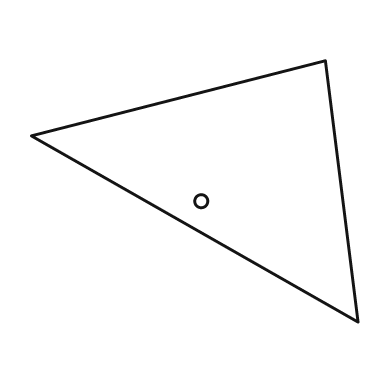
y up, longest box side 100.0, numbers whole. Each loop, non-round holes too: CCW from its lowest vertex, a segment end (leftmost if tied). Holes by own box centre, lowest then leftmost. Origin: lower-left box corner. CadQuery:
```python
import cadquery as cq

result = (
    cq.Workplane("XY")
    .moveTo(100.0, 0.0)
    .lineTo(90.0, 80.0)
    .lineTo(0.0, 57.0)
    .close()
    .moveTo(52.0, 37.0)
    .circle(2.0)
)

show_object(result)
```